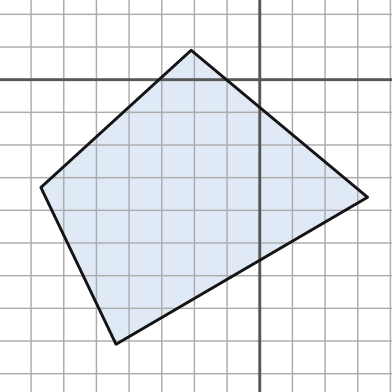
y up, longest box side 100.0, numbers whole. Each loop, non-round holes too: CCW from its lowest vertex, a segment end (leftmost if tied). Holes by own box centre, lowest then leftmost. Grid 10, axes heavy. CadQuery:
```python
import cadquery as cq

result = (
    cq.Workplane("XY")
    .moveTo(-44.0, -81.0)
    .lineTo(33.0, -36.0)
    .lineTo(-21.0, 9.0)
    .lineTo(-67.0, -33.0)
    .close()
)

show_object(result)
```